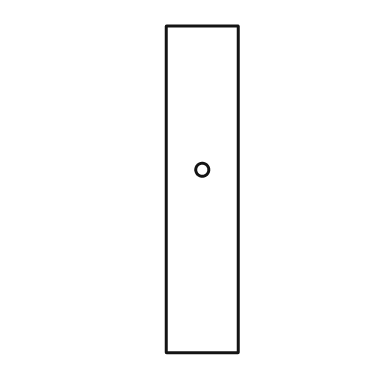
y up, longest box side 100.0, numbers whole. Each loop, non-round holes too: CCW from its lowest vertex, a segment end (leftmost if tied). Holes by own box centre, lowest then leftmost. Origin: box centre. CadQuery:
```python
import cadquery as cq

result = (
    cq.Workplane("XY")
    .moveTo(-11.0, -50.0)
    .lineTo(11.0, -50.0)
    .lineTo(11.0, 50.0)
    .lineTo(-11.0, 50.0)
    .close()
    .moveTo(0.0, 6.0)
    .circle(2.0)
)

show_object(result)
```